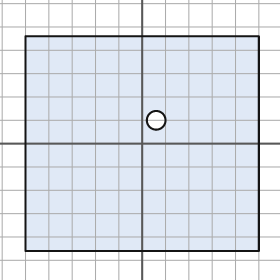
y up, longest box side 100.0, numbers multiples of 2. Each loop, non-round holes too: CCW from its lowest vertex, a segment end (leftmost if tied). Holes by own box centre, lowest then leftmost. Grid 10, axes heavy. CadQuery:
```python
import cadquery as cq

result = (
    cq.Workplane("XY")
    .moveTo(-50.0, -46.0)
    .lineTo(50.0, -46.0)
    .lineTo(50.0, 46.0)
    .lineTo(-50.0, 46.0)
    .close()
    .moveTo(6.0, 10.0)
    .circle(4.0)
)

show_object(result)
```